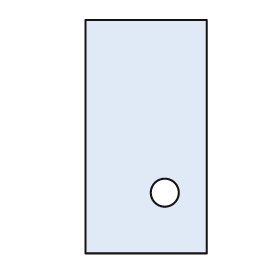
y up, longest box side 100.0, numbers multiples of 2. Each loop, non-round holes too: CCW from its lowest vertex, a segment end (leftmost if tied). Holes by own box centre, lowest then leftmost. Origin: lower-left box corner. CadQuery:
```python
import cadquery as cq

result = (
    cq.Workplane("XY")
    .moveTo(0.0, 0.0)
    .lineTo(52.0, 0.0)
    .lineTo(52.0, 100.0)
    .lineTo(0.0, 100.0)
    .close()
    .moveTo(34.0, 26.0)
    .circle(6.0)
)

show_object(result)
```